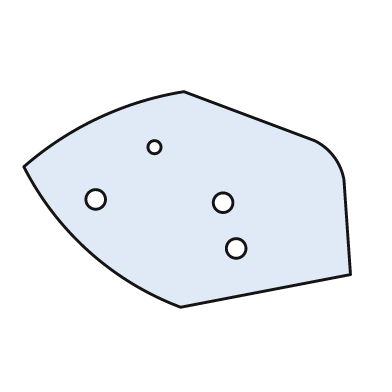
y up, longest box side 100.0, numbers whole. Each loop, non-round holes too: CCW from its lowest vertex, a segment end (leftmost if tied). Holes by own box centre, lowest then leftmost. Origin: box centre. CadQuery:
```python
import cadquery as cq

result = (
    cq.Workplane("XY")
    .moveTo(-2.0, -33.0)
    .lineTo(50.0, -23.0)
    .lineTo(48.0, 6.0)
    .threePointArc((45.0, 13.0), (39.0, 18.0))
    .lineTo(-1.0, 33.0)
    .threePointArc((-27.0, 25.0), (-50.0, 10.0))
    .threePointArc((-30.0, -16.0), (-2.0, -33.0))
    .close()
    .moveTo(15.0, -15.0)
    .circle(3.0)
    .moveTo(11.0, -1.0)
    .circle(3.0)
    .moveTo(-28.0, 0.0)
    .circle(3.0)
    .moveTo(-10.0, 16.0)
    .circle(2.0)
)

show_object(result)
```